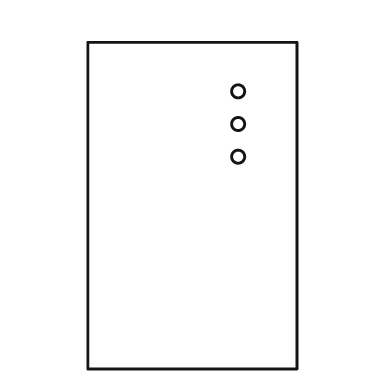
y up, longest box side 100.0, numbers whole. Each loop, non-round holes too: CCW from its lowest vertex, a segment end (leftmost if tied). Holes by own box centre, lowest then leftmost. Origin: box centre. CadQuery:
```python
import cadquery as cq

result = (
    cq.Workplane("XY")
    .moveTo(-32.0, -50.0)
    .lineTo(32.0, -50.0)
    .lineTo(32.0, 50.0)
    .lineTo(-32.0, 50.0)
    .close()
    .moveTo(14.0, 15.0)
    .circle(2.0)
    .moveTo(14.0, 25.0)
    .circle(2.0)
    .moveTo(14.0, 35.0)
    .circle(2.0)
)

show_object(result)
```